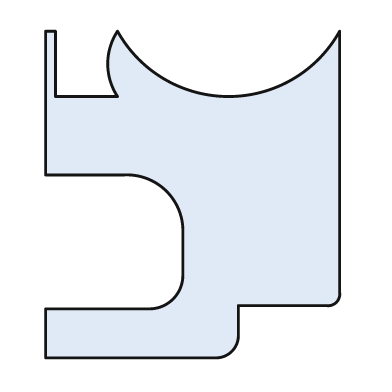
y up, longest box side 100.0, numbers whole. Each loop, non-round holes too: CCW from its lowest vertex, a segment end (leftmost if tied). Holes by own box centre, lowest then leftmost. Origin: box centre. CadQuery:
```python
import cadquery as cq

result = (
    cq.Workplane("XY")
    .moveTo(-45.0, -50.0)
    .lineTo(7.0, -50.0)
    .threePointArc((12.0, -48.0), (14.0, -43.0))
    .lineTo(14.0, -34.0)
    .lineTo(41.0, -34.0)
    .threePointArc((44.0, -33.0), (45.0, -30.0))
    .lineTo(45.0, 50.0)
    .threePointArc((11.0, 30.0), (-23.0, 50.0))
    .threePointArc((-26.0, 40.0), (-23.0, 30.0))
    .lineTo(-42.0, 30.0)
    .lineTo(-42.0, 50.0)
    .lineTo(-45.0, 50.0)
    .lineTo(-45.0, 6.0)
    .lineTo(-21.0, 6.0)
    .threePointArc((-8.0, 1.0), (-3.0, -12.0))
    .lineTo(-3.0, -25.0)
    .threePointArc((-6.0, -32.0), (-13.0, -35.0))
    .lineTo(-45.0, -35.0)
    .close()
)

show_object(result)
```